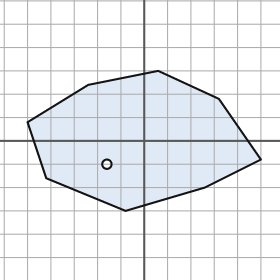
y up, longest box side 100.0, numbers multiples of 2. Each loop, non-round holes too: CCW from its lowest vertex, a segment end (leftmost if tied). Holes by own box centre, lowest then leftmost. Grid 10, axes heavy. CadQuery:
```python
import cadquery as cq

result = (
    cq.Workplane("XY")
    .moveTo(-8.0, -30.0)
    .lineTo(26.0, -20.0)
    .lineTo(50.0, -8.0)
    .lineTo(32.0, 18.0)
    .lineTo(6.0, 30.0)
    .lineTo(-24.0, 24.0)
    .lineTo(-50.0, 8.0)
    .lineTo(-42.0, -16.0)
    .close()
    .moveTo(-16.0, -10.0)
    .circle(2.0)
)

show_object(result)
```